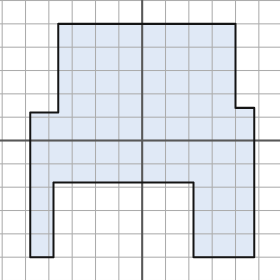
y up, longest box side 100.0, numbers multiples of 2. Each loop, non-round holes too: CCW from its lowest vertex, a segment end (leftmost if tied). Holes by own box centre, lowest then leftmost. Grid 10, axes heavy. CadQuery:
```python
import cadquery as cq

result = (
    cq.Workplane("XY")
    .moveTo(-48.0, -50.0)
    .lineTo(-38.0, -50.0)
    .lineTo(-38.0, -18.0)
    .lineTo(22.0, -18.0)
    .lineTo(22.0, -50.0)
    .lineTo(48.0, -50.0)
    .lineTo(48.0, 14.0)
    .lineTo(40.0, 14.0)
    .lineTo(40.0, 50.0)
    .lineTo(-36.0, 50.0)
    .lineTo(-36.0, 12.0)
    .lineTo(-48.0, 12.0)
    .close()
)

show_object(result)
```